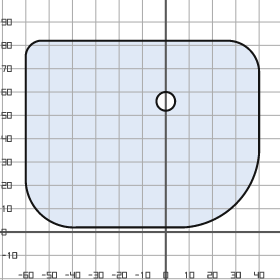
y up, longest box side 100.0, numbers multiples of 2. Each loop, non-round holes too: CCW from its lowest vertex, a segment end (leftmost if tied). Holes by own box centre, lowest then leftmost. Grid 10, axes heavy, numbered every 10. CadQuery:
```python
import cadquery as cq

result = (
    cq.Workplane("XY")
    .moveTo(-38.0, 2.0)
    .lineTo(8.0, 2.0)
    .threePointArc((30.0, 12.0), (40.0, 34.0))
    .lineTo(40.0, 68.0)
    .threePointArc((36.0, 78.0), (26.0, 82.0))
    .lineTo(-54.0, 82.0)
    .threePointArc((-58.0, 80.0), (-60.0, 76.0))
    .lineTo(-60.0, 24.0)
    .threePointArc((-54.0, 8.0), (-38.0, 2.0))
    .close()
    .moveTo(0.0, 56.0)
    .circle(4.0)
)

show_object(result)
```